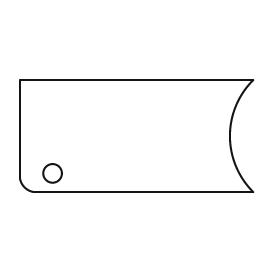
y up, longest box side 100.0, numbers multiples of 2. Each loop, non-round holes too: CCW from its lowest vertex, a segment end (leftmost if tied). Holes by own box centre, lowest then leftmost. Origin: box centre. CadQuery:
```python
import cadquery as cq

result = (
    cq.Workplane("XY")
    .moveTo(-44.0, -24.0)
    .lineTo(50.0, -24.0)
    .threePointArc((40.0, 0.0), (50.0, 24.0))
    .lineTo(-50.0, 24.0)
    .lineTo(-50.0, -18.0)
    .threePointArc((-48.0, -22.0), (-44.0, -24.0))
    .close()
    .moveTo(-36.0, -16.0)
    .circle(4.0)
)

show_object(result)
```